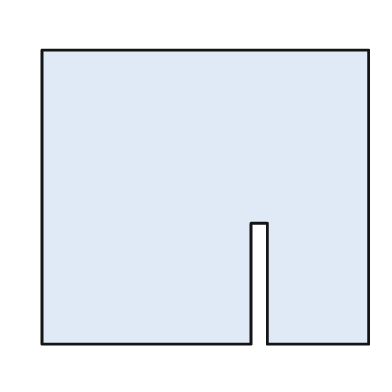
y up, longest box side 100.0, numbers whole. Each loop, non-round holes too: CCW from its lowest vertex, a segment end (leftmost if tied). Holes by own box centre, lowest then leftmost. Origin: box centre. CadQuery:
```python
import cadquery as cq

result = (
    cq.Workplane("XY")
    .moveTo(-50.0, -45.0)
    .lineTo(14.0, -45.0)
    .lineTo(14.0, -8.0)
    .lineTo(19.0, -8.0)
    .lineTo(19.0, -45.0)
    .lineTo(50.0, -45.0)
    .lineTo(50.0, 45.0)
    .lineTo(-50.0, 45.0)
    .close()
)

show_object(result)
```